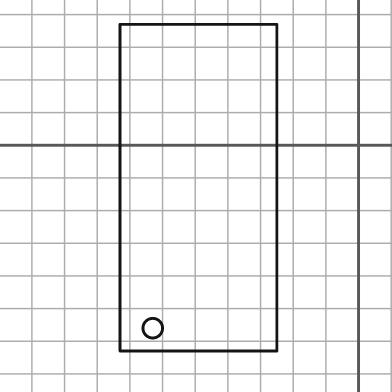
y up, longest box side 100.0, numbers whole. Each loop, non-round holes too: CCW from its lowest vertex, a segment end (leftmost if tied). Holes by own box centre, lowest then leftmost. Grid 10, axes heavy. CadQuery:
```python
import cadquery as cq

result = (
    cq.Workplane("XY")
    .moveTo(-73.0, -63.0)
    .lineTo(-25.0, -63.0)
    .lineTo(-25.0, 37.0)
    .lineTo(-73.0, 37.0)
    .close()
    .moveTo(-63.0, -56.0)
    .circle(3.0)
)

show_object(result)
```